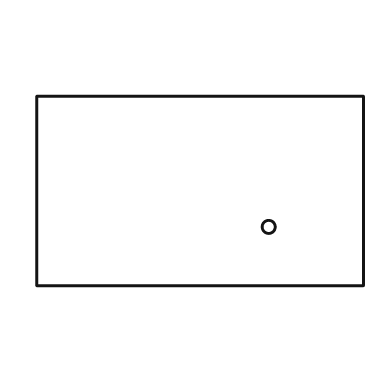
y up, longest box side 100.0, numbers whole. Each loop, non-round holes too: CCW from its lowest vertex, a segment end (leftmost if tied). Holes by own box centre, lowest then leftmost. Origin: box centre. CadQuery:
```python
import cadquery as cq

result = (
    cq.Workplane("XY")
    .moveTo(-50.0, -29.0)
    .lineTo(50.0, -29.0)
    .lineTo(50.0, 29.0)
    .lineTo(-50.0, 29.0)
    .close()
    .moveTo(21.0, -11.0)
    .circle(2.0)
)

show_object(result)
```